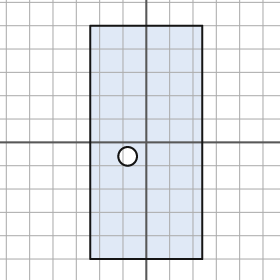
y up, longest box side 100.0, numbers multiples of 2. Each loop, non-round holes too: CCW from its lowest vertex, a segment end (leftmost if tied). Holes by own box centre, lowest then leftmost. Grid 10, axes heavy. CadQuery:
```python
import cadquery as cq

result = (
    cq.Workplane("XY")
    .moveTo(-24.0, -50.0)
    .lineTo(24.0, -50.0)
    .lineTo(24.0, 50.0)
    .lineTo(-24.0, 50.0)
    .close()
    .moveTo(-8.0, -6.0)
    .circle(4.0)
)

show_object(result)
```